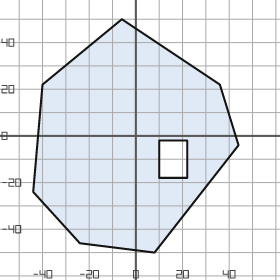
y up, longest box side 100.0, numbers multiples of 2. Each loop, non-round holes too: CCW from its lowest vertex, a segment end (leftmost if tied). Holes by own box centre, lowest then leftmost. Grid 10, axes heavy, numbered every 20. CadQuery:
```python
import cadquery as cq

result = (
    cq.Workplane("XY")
    .moveTo(8.0, -50.0)
    .lineTo(44.0, -4.0)
    .lineTo(36.0, 22.0)
    .lineTo(-6.0, 50.0)
    .lineTo(-40.0, 22.0)
    .lineTo(-44.0, -24.0)
    .lineTo(-24.0, -46.0)
    .close()
    .moveTo(10.0, -18.0)
    .lineTo(22.0, -18.0)
    .lineTo(22.0, -2.0)
    .lineTo(10.0, -2.0)
    .close()
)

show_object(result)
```